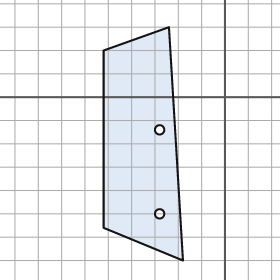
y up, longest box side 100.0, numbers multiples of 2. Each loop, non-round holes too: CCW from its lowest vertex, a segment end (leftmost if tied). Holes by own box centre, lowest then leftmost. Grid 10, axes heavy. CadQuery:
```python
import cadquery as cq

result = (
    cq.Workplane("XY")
    .moveTo(-18.0, -70.0)
    .lineTo(-24.0, 30.0)
    .lineTo(-52.0, 20.0)
    .lineTo(-52.0, -56.0)
    .close()
    .moveTo(-28.0, -50.0)
    .circle(2.0)
    .moveTo(-28.0, -14.0)
    .circle(2.0)
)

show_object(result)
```